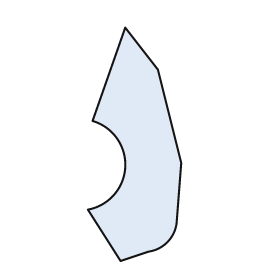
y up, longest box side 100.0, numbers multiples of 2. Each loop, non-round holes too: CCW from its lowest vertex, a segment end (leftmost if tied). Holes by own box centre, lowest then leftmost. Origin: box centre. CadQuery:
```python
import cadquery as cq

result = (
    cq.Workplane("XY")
    .moveTo(-6.0, -50.0)
    .lineTo(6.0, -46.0)
    .threePointArc((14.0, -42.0), (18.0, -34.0))
    .lineTo(20.0, -8.0)
    .lineTo(10.0, 32.0)
    .lineTo(-4.0, 50.0)
    .lineTo(-18.0, 10.0)
    .threePointArc((-4.0, -10.0), (-20.0, -28.0))
    .close()
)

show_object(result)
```